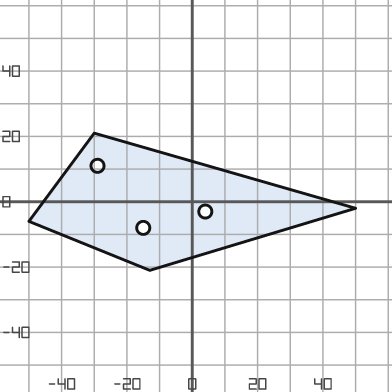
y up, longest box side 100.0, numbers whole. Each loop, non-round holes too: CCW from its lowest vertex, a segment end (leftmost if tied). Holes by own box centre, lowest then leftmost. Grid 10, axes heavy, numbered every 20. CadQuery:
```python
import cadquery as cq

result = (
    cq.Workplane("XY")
    .moveTo(-13.0, -21.0)
    .lineTo(50.0, -2.0)
    .lineTo(-30.0, 21.0)
    .lineTo(-50.0, -6.0)
    .close()
    .moveTo(-15.0, -8.0)
    .circle(2.0)
    .moveTo(4.0, -3.0)
    .circle(2.0)
    .moveTo(-29.0, 11.0)
    .circle(2.0)
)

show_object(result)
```